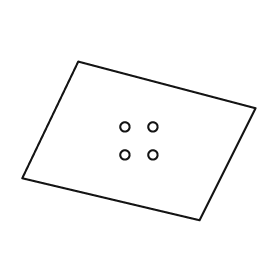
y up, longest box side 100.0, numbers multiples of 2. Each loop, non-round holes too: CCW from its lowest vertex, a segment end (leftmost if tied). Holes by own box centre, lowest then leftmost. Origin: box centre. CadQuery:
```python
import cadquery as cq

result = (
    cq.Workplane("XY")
    .moveTo(26.0, -34.0)
    .lineTo(50.0, 14.0)
    .lineTo(-26.0, 34.0)
    .lineTo(-50.0, -16.0)
    .close()
    .moveTo(-6.0, -6.0)
    .circle(2.0)
    .moveTo(6.0, -6.0)
    .circle(2.0)
    .moveTo(-6.0, 6.0)
    .circle(2.0)
    .moveTo(6.0, 6.0)
    .circle(2.0)
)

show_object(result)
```